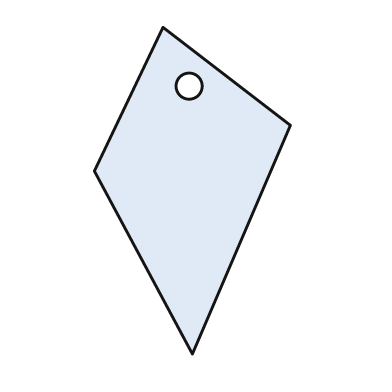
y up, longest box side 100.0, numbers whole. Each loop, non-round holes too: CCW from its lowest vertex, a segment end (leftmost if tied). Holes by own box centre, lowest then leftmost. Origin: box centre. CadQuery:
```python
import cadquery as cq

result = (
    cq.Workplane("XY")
    .moveTo(0.0, -50.0)
    .lineTo(30.0, 20.0)
    .lineTo(-9.0, 50.0)
    .lineTo(-30.0, 6.0)
    .close()
    .moveTo(-1.0, 32.0)
    .circle(4.0)
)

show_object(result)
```